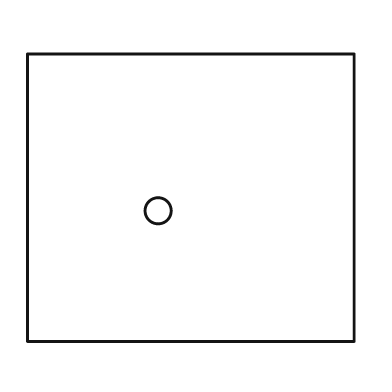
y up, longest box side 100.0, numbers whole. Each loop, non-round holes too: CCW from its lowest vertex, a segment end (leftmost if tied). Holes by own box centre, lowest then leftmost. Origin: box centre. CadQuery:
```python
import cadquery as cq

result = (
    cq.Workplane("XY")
    .moveTo(-50.0, -44.0)
    .lineTo(50.0, -44.0)
    .lineTo(50.0, 44.0)
    .lineTo(-50.0, 44.0)
    .close()
    .moveTo(-10.0, -4.0)
    .circle(4.0)
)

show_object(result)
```